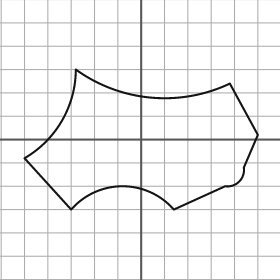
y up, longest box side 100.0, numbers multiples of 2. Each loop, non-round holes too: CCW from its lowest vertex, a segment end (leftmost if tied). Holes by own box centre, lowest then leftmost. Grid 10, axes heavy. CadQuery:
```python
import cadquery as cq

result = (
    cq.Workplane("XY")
    .moveTo(-30.0, -30.0)
    .threePointArc((-8.0, -20.0), (14.0, -30.0))
    .lineTo(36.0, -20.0)
    .threePointArc((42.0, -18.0), (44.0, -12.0))
    .lineTo(50.0, 2.0)
    .lineTo(38.0, 24.0)
    .threePointArc((4.0, 18.0), (-28.0, 30.0))
    .threePointArc((-34.0, 8.0), (-50.0, -8.0))
    .close()
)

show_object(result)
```